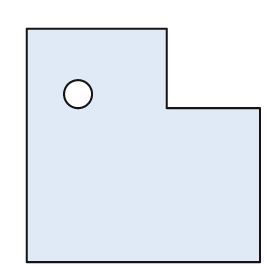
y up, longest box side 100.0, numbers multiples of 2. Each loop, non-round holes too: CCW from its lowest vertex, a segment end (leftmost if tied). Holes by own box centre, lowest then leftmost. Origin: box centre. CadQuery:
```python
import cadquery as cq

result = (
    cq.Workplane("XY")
    .moveTo(-50.0, -50.0)
    .lineTo(50.0, -50.0)
    .lineTo(50.0, 16.0)
    .lineTo(10.0, 16.0)
    .lineTo(10.0, 50.0)
    .lineTo(-50.0, 50.0)
    .close()
    .moveTo(-28.0, 22.0)
    .circle(6.0)
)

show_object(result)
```